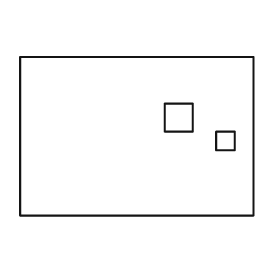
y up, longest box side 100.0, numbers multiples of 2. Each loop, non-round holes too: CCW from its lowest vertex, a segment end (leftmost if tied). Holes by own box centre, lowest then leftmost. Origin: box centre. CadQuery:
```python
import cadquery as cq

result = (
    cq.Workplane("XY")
    .moveTo(-50.0, -34.0)
    .lineTo(50.0, -34.0)
    .lineTo(50.0, 34.0)
    .lineTo(-50.0, 34.0)
    .close()
    .moveTo(34.0, -6.0)
    .lineTo(42.0, -6.0)
    .lineTo(42.0, 2.0)
    .lineTo(34.0, 2.0)
    .close()
    .moveTo(12.0, 2.0)
    .lineTo(24.0, 2.0)
    .lineTo(24.0, 14.0)
    .lineTo(12.0, 14.0)
    .close()
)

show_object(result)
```